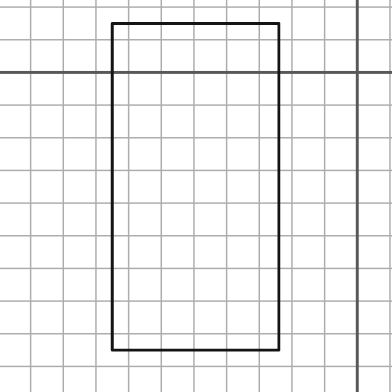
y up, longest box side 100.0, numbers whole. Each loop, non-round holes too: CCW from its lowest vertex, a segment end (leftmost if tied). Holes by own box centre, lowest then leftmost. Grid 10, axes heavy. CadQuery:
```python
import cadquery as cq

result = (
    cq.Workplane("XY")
    .moveTo(-75.0, -85.0)
    .lineTo(-24.0, -85.0)
    .lineTo(-24.0, 15.0)
    .lineTo(-75.0, 15.0)
    .close()
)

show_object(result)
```